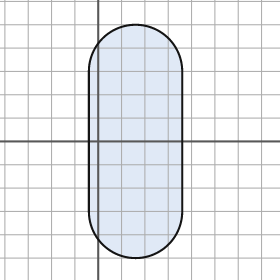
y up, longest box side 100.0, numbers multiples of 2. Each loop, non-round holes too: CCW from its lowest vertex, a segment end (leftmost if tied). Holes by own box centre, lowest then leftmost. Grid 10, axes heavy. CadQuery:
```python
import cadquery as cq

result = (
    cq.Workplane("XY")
    .moveTo(-4.0, -30.0)
    .threePointArc((16.0, -50.0), (36.0, -30.0))
    .lineTo(36.0, 30.0)
    .threePointArc((16.0, 50.0), (-4.0, 30.0))
    .close()
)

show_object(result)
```